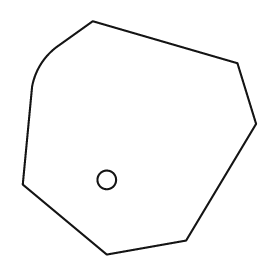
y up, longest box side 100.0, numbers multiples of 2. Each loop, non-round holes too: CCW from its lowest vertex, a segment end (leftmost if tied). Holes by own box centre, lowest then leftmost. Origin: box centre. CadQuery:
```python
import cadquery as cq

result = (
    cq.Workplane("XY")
    .moveTo(-14.0, -50.0)
    .lineTo(20.0, -44.0)
    .lineTo(50.0, 6.0)
    .lineTo(42.0, 32.0)
    .lineTo(-20.0, 50.0)
    .lineTo(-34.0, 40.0)
    .threePointArc((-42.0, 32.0), (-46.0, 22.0))
    .lineTo(-50.0, -20.0)
    .close()
    .moveTo(-14.0, -18.0)
    .circle(4.0)
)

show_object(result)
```